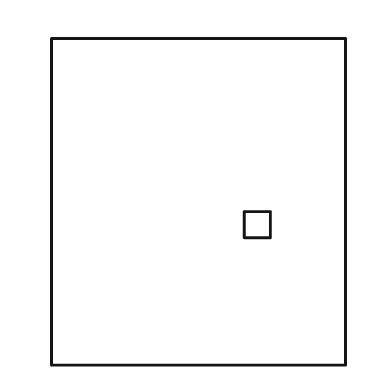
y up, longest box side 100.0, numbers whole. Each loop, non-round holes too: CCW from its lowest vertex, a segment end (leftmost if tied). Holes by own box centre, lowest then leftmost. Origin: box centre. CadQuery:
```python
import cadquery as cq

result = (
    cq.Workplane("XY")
    .moveTo(-45.0, -50.0)
    .lineTo(45.0, -50.0)
    .lineTo(45.0, 50.0)
    .lineTo(-45.0, 50.0)
    .close()
    .moveTo(14.0, -11.0)
    .lineTo(22.0, -11.0)
    .lineTo(22.0, -3.0)
    .lineTo(14.0, -3.0)
    .close()
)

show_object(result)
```